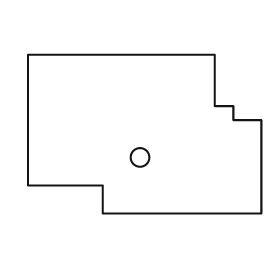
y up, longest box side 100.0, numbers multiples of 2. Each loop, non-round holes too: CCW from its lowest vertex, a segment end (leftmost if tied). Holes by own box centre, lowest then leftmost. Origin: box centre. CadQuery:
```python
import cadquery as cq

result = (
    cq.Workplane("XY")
    .moveTo(-18.0, -34.0)
    .lineTo(50.0, -34.0)
    .lineTo(50.0, 6.0)
    .lineTo(38.0, 6.0)
    .lineTo(38.0, 12.0)
    .lineTo(30.0, 12.0)
    .lineTo(30.0, 34.0)
    .lineTo(-50.0, 34.0)
    .lineTo(-50.0, -22.0)
    .lineTo(-18.0, -22.0)
    .close()
    .moveTo(-2.0, -10.0)
    .circle(4.0)
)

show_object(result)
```